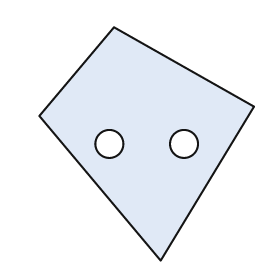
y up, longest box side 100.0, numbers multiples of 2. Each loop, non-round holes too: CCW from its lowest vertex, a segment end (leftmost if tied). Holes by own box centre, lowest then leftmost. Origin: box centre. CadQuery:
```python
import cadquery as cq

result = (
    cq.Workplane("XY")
    .moveTo(6.0, -50.0)
    .lineTo(46.0, 16.0)
    .lineTo(-14.0, 50.0)
    .lineTo(-46.0, 12.0)
    .close()
    .moveTo(-16.0, 0.0)
    .circle(6.0)
    .moveTo(16.0, 0.0)
    .circle(6.0)
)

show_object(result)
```